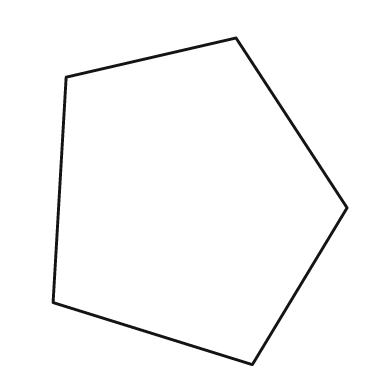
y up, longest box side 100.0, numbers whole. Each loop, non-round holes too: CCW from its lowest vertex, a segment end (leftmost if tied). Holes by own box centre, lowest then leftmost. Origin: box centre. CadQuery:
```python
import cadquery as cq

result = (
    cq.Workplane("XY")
    .moveTo(16.0, -50.0)
    .lineTo(45.0, -2.0)
    .lineTo(11.0, 50.0)
    .lineTo(-41.0, 38.0)
    .lineTo(-45.0, -31.0)
    .close()
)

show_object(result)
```